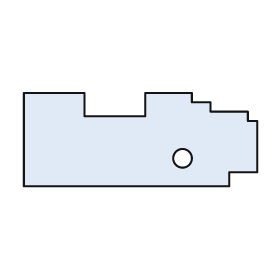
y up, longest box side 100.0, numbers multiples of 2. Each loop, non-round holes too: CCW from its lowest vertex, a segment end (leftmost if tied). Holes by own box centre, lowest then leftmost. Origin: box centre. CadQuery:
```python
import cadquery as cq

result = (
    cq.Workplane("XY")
    .moveTo(-50.0, -20.0)
    .lineTo(38.0, -20.0)
    .lineTo(38.0, -14.0)
    .lineTo(50.0, -14.0)
    .lineTo(50.0, 8.0)
    .lineTo(46.0, 8.0)
    .lineTo(46.0, 12.0)
    .lineTo(30.0, 12.0)
    .lineTo(30.0, 16.0)
    .lineTo(22.0, 16.0)
    .lineTo(22.0, 20.0)
    .lineTo(2.0, 20.0)
    .lineTo(2.0, 10.0)
    .lineTo(-24.0, 10.0)
    .lineTo(-24.0, 20.0)
    .lineTo(-50.0, 20.0)
    .close()
    .moveTo(18.0, -8.0)
    .circle(4.0)
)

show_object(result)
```